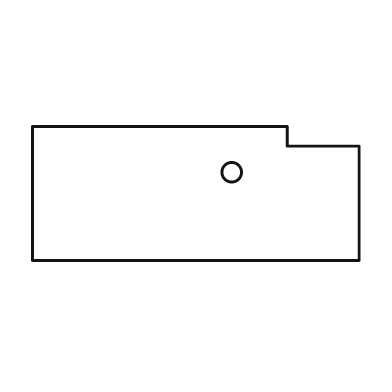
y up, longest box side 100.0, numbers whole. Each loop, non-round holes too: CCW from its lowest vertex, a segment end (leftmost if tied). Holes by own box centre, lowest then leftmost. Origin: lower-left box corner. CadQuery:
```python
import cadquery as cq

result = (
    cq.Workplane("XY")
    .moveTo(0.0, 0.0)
    .lineTo(100.0, 0.0)
    .lineTo(100.0, 35.0)
    .lineTo(78.0, 35.0)
    .lineTo(78.0, 41.0)
    .lineTo(0.0, 41.0)
    .close()
    .moveTo(61.0, 27.0)
    .circle(3.0)
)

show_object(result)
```